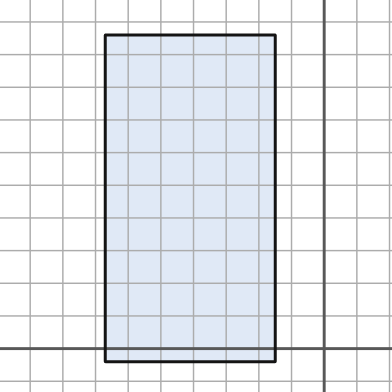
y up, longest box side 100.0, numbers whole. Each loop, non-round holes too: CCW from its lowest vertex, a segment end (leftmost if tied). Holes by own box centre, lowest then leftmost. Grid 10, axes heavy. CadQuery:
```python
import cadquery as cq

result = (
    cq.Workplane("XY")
    .moveTo(-67.0, -4.0)
    .lineTo(-15.0, -4.0)
    .lineTo(-15.0, 96.0)
    .lineTo(-67.0, 96.0)
    .close()
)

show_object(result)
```